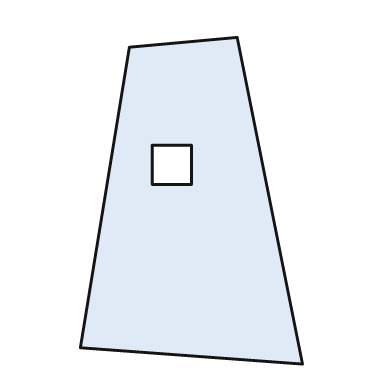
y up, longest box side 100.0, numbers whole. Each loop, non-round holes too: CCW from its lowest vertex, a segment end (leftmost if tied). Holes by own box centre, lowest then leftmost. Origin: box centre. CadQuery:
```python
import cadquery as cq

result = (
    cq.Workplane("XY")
    .moveTo(34.0, -50.0)
    .lineTo(14.0, 50.0)
    .lineTo(-19.0, 47.0)
    .lineTo(-34.0, -45.0)
    .close()
    .moveTo(-12.0, 5.0)
    .lineTo(0.0, 5.0)
    .lineTo(0.0, 17.0)
    .lineTo(-12.0, 17.0)
    .close()
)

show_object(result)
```